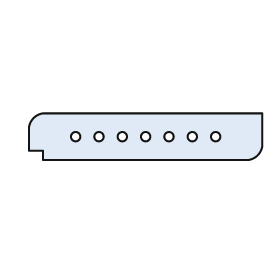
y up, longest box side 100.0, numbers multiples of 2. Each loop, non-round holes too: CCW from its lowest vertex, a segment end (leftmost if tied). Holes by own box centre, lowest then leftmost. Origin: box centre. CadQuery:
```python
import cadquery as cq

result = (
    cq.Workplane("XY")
    .moveTo(-44.0, -10.0)
    .lineTo(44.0, -10.0)
    .threePointArc((48.0, -8.0), (50.0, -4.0))
    .lineTo(50.0, 10.0)
    .lineTo(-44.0, 10.0)
    .threePointArc((-48.0, 8.0), (-50.0, 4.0))
    .lineTo(-50.0, -6.0)
    .lineTo(-44.0, -6.0)
    .close()
    .moveTo(-30.0, 0.0)
    .circle(2.0)
    .moveTo(-20.0, 0.0)
    .circle(2.0)
    .moveTo(-10.0, 0.0)
    .circle(2.0)
    .moveTo(0.0, 0.0)
    .circle(2.0)
    .moveTo(10.0, 0.0)
    .circle(2.0)
    .moveTo(20.0, 0.0)
    .circle(2.0)
    .moveTo(30.0, 0.0)
    .circle(2.0)
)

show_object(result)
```